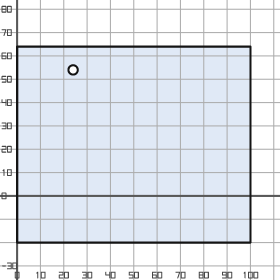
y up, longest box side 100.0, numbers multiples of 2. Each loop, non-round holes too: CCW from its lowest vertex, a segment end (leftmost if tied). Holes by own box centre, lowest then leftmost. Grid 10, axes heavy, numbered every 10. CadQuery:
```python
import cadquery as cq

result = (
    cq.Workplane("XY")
    .moveTo(0.0, -20.0)
    .lineTo(100.0, -20.0)
    .lineTo(100.0, 64.0)
    .lineTo(0.0, 64.0)
    .close()
    .moveTo(24.0, 54.0)
    .circle(2.0)
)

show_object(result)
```